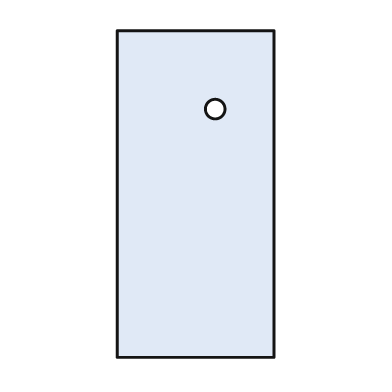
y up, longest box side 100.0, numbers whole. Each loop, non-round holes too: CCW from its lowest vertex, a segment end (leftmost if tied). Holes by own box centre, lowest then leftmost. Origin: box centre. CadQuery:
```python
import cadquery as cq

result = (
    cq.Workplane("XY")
    .moveTo(-24.0, -50.0)
    .lineTo(24.0, -50.0)
    .lineTo(24.0, 50.0)
    .lineTo(-24.0, 50.0)
    .close()
    .moveTo(6.0, 26.0)
    .circle(3.0)
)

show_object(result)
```